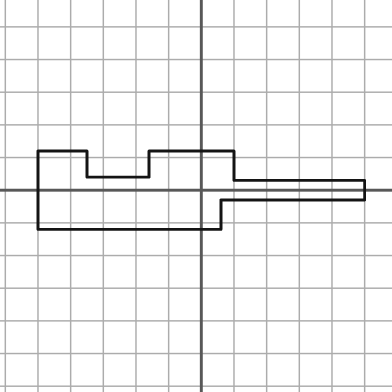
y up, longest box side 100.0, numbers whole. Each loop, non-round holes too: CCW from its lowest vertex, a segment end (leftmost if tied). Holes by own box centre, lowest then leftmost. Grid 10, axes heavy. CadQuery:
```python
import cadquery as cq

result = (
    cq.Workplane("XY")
    .moveTo(-50.0, -12.0)
    .lineTo(6.0, -12.0)
    .lineTo(6.0, -3.0)
    .lineTo(50.0, -3.0)
    .lineTo(50.0, 3.0)
    .lineTo(10.0, 3.0)
    .lineTo(10.0, 12.0)
    .lineTo(-16.0, 12.0)
    .lineTo(-16.0, 4.0)
    .lineTo(-35.0, 4.0)
    .lineTo(-35.0, 12.0)
    .lineTo(-50.0, 12.0)
    .close()
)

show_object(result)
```